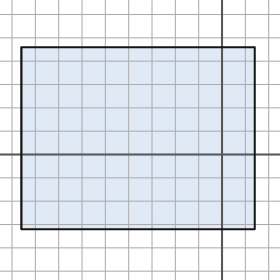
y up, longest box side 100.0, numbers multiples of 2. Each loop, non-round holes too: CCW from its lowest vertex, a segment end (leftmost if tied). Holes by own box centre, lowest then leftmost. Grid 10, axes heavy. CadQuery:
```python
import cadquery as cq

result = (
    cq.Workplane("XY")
    .moveTo(-86.0, -32.0)
    .lineTo(14.0, -32.0)
    .lineTo(14.0, 46.0)
    .lineTo(-86.0, 46.0)
    .close()
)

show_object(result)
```